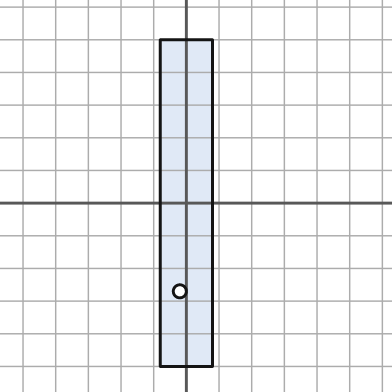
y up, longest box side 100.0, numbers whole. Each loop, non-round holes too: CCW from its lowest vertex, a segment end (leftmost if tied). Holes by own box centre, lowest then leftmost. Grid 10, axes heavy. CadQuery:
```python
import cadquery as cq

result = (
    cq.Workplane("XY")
    .moveTo(-8.0, -50.0)
    .lineTo(8.0, -50.0)
    .lineTo(8.0, 50.0)
    .lineTo(-8.0, 50.0)
    .close()
    .moveTo(-2.0, -27.0)
    .circle(2.0)
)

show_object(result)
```